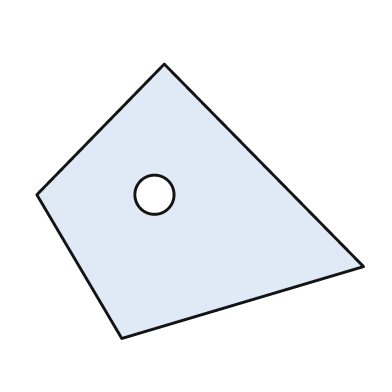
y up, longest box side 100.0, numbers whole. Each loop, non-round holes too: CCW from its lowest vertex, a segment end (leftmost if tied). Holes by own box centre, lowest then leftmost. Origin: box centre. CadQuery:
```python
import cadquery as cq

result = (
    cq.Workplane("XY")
    .moveTo(-24.0, -42.0)
    .lineTo(50.0, -20.0)
    .lineTo(-11.0, 42.0)
    .lineTo(-50.0, 2.0)
    .close()
    .moveTo(-14.0, 2.0)
    .circle(6.0)
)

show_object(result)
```